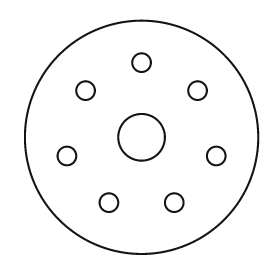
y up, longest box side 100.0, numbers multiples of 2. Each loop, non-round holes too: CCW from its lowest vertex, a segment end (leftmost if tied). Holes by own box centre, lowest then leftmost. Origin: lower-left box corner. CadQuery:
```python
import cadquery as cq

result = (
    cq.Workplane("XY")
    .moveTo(50.0, 50.0)
    .circle(50.0)
    .moveTo(36.0, 22.0)
    .circle(4.0)
    .moveTo(64.0, 22.0)
    .circle(4.0)
    .moveTo(18.0, 42.0)
    .circle(4.0)
    .moveTo(82.0, 42.0)
    .circle(4.0)
    .moveTo(50.0, 50.0)
    .circle(10.0)
    .moveTo(26.0, 70.0)
    .circle(4.0)
    .moveTo(74.0, 70.0)
    .circle(4.0)
    .moveTo(50.0, 82.0)
    .circle(4.0)
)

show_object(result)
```